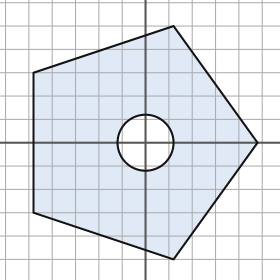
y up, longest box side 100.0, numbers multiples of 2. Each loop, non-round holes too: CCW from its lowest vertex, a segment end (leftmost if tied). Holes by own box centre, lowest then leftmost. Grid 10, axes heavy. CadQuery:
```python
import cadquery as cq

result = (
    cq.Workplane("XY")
    .moveTo(12.0, -50.0)
    .lineTo(48.0, 0.0)
    .lineTo(12.0, 50.0)
    .lineTo(-48.0, 30.0)
    .lineTo(-48.0, -30.0)
    .close()
    .moveTo(0.0, 0.0)
    .circle(12.0)
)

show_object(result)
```